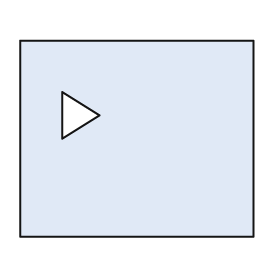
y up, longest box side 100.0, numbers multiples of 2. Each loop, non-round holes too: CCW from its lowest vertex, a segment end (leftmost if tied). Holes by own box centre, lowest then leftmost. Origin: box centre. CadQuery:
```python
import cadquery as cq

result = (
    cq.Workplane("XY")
    .moveTo(-50.0, -42.0)
    .lineTo(50.0, -42.0)
    .lineTo(50.0, 42.0)
    .lineTo(-50.0, 42.0)
    .close()
    .moveTo(-32.0, 0.0)
    .lineTo(-16.0, 10.0)
    .lineTo(-32.0, 20.0)
    .close()
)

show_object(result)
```